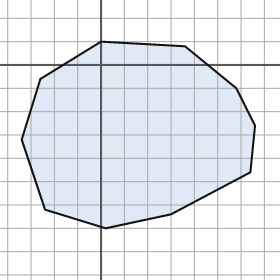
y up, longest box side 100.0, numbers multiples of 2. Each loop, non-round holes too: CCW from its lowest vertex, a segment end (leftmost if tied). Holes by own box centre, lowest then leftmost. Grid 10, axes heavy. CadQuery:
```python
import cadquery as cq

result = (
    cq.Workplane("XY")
    .moveTo(2.0, -70.0)
    .lineTo(30.0, -64.0)
    .lineTo(64.0, -46.0)
    .lineTo(66.0, -26.0)
    .lineTo(58.0, -10.0)
    .lineTo(36.0, 8.0)
    .lineTo(0.0, 10.0)
    .lineTo(-26.0, -6.0)
    .lineTo(-34.0, -32.0)
    .lineTo(-24.0, -62.0)
    .close()
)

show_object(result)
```